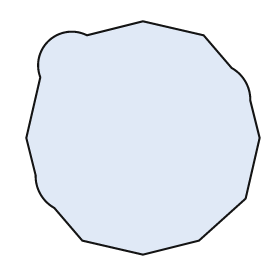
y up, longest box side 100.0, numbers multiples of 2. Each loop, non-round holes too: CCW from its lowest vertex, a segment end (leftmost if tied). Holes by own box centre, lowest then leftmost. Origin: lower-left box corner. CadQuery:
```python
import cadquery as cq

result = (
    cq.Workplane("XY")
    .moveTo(50.0, 0.0)
    .lineTo(74.0, 6.0)
    .lineTo(94.0, 24.0)
    .lineTo(100.0, 50.0)
    .lineTo(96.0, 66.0)
    .threePointArc((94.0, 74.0), (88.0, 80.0))
    .lineTo(76.0, 94.0)
    .lineTo(50.0, 100.0)
    .lineTo(26.0, 94.0)
    .threePointArc((10.0, 92.0), (6.0, 76.0))
    .lineTo(0.0, 50.0)
    .lineTo(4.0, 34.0)
    .threePointArc((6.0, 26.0), (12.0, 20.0))
    .lineTo(24.0, 6.0)
    .close()
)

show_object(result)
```